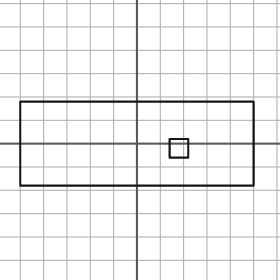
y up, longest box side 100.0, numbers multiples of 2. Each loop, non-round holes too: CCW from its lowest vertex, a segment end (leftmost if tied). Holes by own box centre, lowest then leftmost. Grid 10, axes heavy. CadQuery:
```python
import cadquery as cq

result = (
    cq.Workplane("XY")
    .moveTo(-50.0, -18.0)
    .lineTo(50.0, -18.0)
    .lineTo(50.0, 18.0)
    .lineTo(-50.0, 18.0)
    .close()
    .moveTo(14.0, -6.0)
    .lineTo(22.0, -6.0)
    .lineTo(22.0, 2.0)
    .lineTo(14.0, 2.0)
    .close()
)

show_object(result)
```